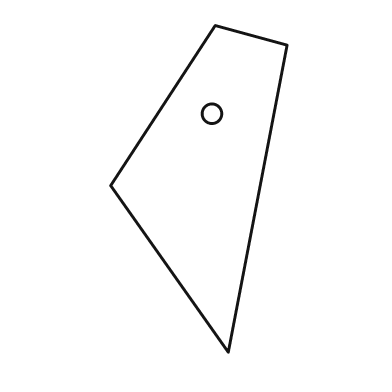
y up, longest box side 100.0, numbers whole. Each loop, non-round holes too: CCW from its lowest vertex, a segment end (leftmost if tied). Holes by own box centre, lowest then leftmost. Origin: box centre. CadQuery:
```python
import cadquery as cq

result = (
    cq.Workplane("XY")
    .moveTo(9.0, -50.0)
    .lineTo(27.0, 44.0)
    .lineTo(5.0, 50.0)
    .lineTo(-27.0, 1.0)
    .close()
    .moveTo(4.0, 23.0)
    .circle(3.0)
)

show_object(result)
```